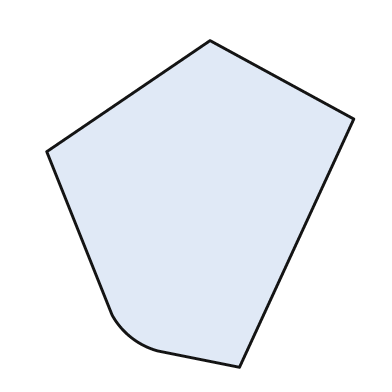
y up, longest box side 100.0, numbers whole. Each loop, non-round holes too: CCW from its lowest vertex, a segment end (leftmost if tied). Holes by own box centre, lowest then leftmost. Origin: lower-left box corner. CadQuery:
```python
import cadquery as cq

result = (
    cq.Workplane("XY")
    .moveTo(59.0, 0.0)
    .lineTo(94.0, 76.0)
    .lineTo(50.0, 100.0)
    .lineTo(0.0, 66.0)
    .lineTo(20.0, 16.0)
    .threePointArc((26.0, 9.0), (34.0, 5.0))
    .close()
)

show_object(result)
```